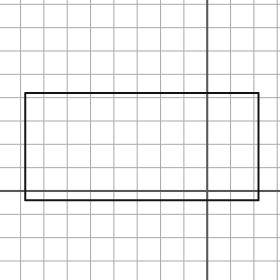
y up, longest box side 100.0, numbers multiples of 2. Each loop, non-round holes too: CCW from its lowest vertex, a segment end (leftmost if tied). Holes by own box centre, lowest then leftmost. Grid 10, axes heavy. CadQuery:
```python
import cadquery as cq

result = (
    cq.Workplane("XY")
    .moveTo(-78.0, -4.0)
    .lineTo(22.0, -4.0)
    .lineTo(22.0, 42.0)
    .lineTo(-78.0, 42.0)
    .close()
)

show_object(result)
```